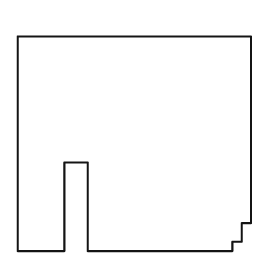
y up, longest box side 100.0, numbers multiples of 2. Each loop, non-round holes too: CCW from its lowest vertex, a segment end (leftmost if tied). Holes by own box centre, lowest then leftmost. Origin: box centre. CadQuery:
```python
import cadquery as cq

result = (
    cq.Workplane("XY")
    .moveTo(-50.0, -46.0)
    .lineTo(-30.0, -46.0)
    .lineTo(-30.0, -8.0)
    .lineTo(-20.0, -8.0)
    .lineTo(-20.0, -46.0)
    .lineTo(42.0, -46.0)
    .lineTo(42.0, -42.0)
    .lineTo(46.0, -42.0)
    .lineTo(46.0, -34.0)
    .lineTo(50.0, -34.0)
    .lineTo(50.0, 46.0)
    .lineTo(-50.0, 46.0)
    .close()
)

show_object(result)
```